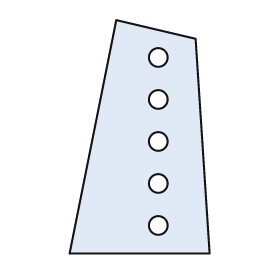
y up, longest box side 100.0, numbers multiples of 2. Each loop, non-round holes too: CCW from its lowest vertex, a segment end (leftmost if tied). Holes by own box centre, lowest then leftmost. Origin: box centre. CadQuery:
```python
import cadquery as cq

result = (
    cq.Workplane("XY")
    .moveTo(-30.0, -50.0)
    .lineTo(30.0, -50.0)
    .lineTo(24.0, 42.0)
    .lineTo(-10.0, 50.0)
    .close()
    .moveTo(8.0, -38.0)
    .circle(4.0)
    .moveTo(8.0, -20.0)
    .circle(4.0)
    .moveTo(8.0, -2.0)
    .circle(4.0)
    .moveTo(8.0, 16.0)
    .circle(4.0)
    .moveTo(8.0, 34.0)
    .circle(4.0)
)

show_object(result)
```